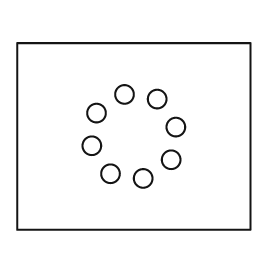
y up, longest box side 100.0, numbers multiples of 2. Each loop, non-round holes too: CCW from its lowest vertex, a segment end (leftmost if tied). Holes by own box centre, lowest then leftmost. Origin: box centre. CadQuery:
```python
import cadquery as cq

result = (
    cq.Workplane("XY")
    .moveTo(-50.0, -40.0)
    .lineTo(50.0, -40.0)
    .lineTo(50.0, 40.0)
    .lineTo(-50.0, 40.0)
    .close()
    .moveTo(4.0, -18.0)
    .circle(4.0)
    .moveTo(-10.0, -16.0)
    .circle(4.0)
    .moveTo(16.0, -10.0)
    .circle(4.0)
    .moveTo(-18.0, -4.0)
    .circle(4.0)
    .moveTo(18.0, 4.0)
    .circle(4.0)
    .moveTo(-16.0, 10.0)
    .circle(4.0)
    .moveTo(10.0, 16.0)
    .circle(4.0)
    .moveTo(-4.0, 18.0)
    .circle(4.0)
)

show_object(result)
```